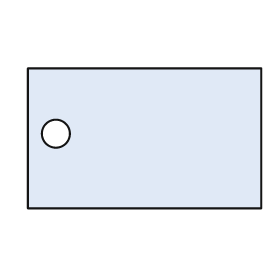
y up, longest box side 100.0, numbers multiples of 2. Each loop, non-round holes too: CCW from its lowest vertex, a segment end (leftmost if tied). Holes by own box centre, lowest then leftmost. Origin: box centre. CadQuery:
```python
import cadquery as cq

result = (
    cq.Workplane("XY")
    .moveTo(-50.0, -30.0)
    .lineTo(50.0, -30.0)
    .lineTo(50.0, 30.0)
    .lineTo(-50.0, 30.0)
    .close()
    .moveTo(-38.0, 2.0)
    .circle(6.0)
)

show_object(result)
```